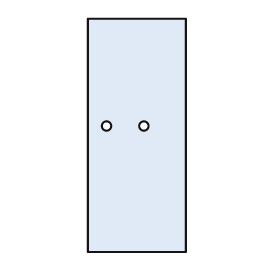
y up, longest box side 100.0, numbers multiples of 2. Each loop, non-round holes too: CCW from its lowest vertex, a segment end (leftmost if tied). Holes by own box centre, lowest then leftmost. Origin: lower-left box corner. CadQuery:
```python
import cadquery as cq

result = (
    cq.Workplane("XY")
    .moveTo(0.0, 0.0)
    .lineTo(42.0, 0.0)
    .lineTo(42.0, 100.0)
    .lineTo(0.0, 100.0)
    .close()
    .moveTo(8.0, 54.0)
    .circle(2.0)
    .moveTo(24.0, 54.0)
    .circle(2.0)
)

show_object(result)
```